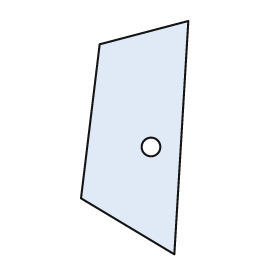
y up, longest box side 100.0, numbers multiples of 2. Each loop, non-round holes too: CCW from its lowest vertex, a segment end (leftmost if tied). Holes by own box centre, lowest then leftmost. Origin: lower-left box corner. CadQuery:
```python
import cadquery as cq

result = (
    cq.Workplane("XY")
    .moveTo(40.0, 0.0)
    .lineTo(46.0, 100.0)
    .lineTo(8.0, 90.0)
    .lineTo(0.0, 24.0)
    .close()
    .moveTo(30.0, 46.0)
    .circle(4.0)
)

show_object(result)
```